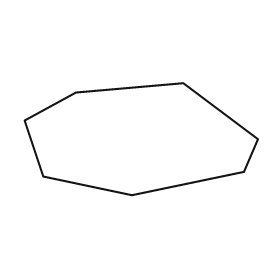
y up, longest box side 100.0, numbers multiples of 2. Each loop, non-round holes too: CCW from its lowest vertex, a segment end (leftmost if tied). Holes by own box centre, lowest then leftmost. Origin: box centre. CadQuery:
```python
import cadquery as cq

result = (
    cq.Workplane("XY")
    .moveTo(-4.0, -24.0)
    .lineTo(44.0, -14.0)
    .lineTo(50.0, 0.0)
    .lineTo(18.0, 24.0)
    .lineTo(-28.0, 20.0)
    .lineTo(-50.0, 8.0)
    .lineTo(-42.0, -16.0)
    .close()
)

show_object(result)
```